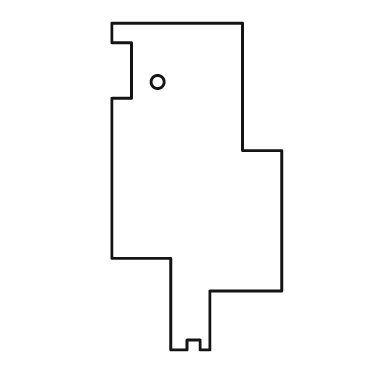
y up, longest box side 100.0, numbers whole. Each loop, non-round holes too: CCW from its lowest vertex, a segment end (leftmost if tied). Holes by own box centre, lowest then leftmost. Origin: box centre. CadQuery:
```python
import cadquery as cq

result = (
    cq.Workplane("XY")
    .moveTo(-8.0, -50.0)
    .lineTo(-3.0, -50.0)
    .lineTo(-3.0, -47.0)
    .lineTo(1.0, -47.0)
    .lineTo(1.0, -50.0)
    .lineTo(4.0, -50.0)
    .lineTo(4.0, -32.0)
    .lineTo(26.0, -32.0)
    .lineTo(26.0, 11.0)
    .lineTo(14.0, 11.0)
    .lineTo(14.0, 50.0)
    .lineTo(-26.0, 50.0)
    .lineTo(-26.0, 44.0)
    .lineTo(-20.0, 44.0)
    .lineTo(-20.0, 27.0)
    .lineTo(-26.0, 27.0)
    .lineTo(-26.0, -22.0)
    .lineTo(-8.0, -22.0)
    .close()
    .moveTo(-12.0, 32.0)
    .circle(2.0)
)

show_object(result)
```